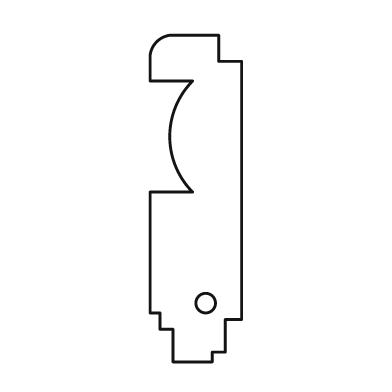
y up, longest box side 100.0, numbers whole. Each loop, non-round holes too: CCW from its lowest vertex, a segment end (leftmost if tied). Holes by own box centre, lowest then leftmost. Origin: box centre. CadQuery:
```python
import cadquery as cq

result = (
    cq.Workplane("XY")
    .moveTo(-7.0, -50.0)
    .lineTo(5.0, -50.0)
    .lineTo(5.0, -47.0)
    .lineTo(9.0, -47.0)
    .lineTo(9.0, -37.0)
    .lineTo(14.0, -37.0)
    .lineTo(14.0, 42.0)
    .lineTo(7.0, 42.0)
    .lineTo(7.0, 50.0)
    .lineTo(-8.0, 50.0)
    .threePointArc((-12.0, 48.0), (-14.0, 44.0))
    .lineTo(-14.0, 36.0)
    .lineTo(-1.0, 36.0)
    .threePointArc((-8.0, 19.0), (-1.0, 2.0))
    .lineTo(-14.0, 2.0)
    .lineTo(-14.0, -35.0)
    .lineTo(-11.0, -35.0)
    .lineTo(-11.0, -40.0)
    .lineTo(-7.0, -40.0)
    .close()
    .moveTo(3.0, -32.0)
    .circle(3.0)
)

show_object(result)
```